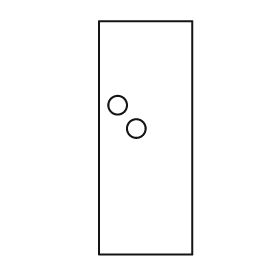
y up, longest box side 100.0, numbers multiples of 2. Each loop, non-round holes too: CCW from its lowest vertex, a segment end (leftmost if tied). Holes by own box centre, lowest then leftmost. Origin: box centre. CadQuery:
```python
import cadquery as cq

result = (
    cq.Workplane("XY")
    .moveTo(-20.0, -50.0)
    .lineTo(20.0, -50.0)
    .lineTo(20.0, 50.0)
    .lineTo(-20.0, 50.0)
    .close()
    .moveTo(-4.0, 4.0)
    .circle(4.0)
    .moveTo(-12.0, 14.0)
    .circle(4.0)
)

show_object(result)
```